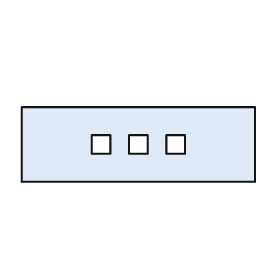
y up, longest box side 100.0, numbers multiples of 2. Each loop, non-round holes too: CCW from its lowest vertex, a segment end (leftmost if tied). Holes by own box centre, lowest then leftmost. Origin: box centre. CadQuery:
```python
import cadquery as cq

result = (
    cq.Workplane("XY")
    .moveTo(-50.0, -16.0)
    .lineTo(50.0, -16.0)
    .lineTo(50.0, 16.0)
    .lineTo(-50.0, 16.0)
    .close()
    .moveTo(-20.0, -4.0)
    .lineTo(-12.0, -4.0)
    .lineTo(-12.0, 4.0)
    .lineTo(-20.0, 4.0)
    .close()
    .moveTo(-4.0, -4.0)
    .lineTo(4.0, -4.0)
    .lineTo(4.0, 4.0)
    .lineTo(-4.0, 4.0)
    .close()
    .moveTo(12.0, -4.0)
    .lineTo(20.0, -4.0)
    .lineTo(20.0, 4.0)
    .lineTo(12.0, 4.0)
    .close()
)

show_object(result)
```